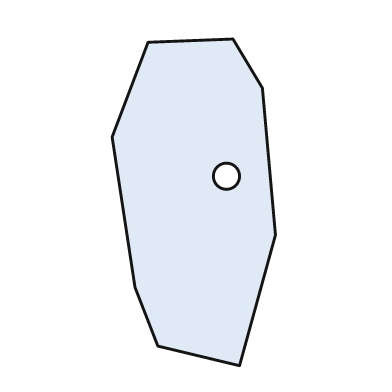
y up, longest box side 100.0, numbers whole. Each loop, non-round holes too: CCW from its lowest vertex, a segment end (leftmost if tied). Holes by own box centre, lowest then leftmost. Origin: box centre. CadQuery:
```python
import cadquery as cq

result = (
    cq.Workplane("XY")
    .moveTo(14.0, -50.0)
    .lineTo(25.0, -10.0)
    .lineTo(21.0, 35.0)
    .lineTo(12.0, 50.0)
    .lineTo(-14.0, 49.0)
    .lineTo(-25.0, 20.0)
    .lineTo(-18.0, -26.0)
    .lineTo(-11.0, -44.0)
    .close()
    .moveTo(10.0, 8.0)
    .circle(4.0)
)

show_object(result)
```